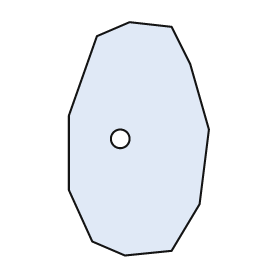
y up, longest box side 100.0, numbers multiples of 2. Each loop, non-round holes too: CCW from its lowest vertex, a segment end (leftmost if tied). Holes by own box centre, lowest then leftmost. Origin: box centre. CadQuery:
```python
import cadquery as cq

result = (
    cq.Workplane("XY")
    .moveTo(-6.0, -50.0)
    .lineTo(14.0, -48.0)
    .lineTo(26.0, -28.0)
    .lineTo(30.0, 4.0)
    .lineTo(22.0, 32.0)
    .lineTo(14.0, 48.0)
    .lineTo(-4.0, 50.0)
    .lineTo(-18.0, 44.0)
    .lineTo(-30.0, 10.0)
    .lineTo(-30.0, -22.0)
    .lineTo(-20.0, -44.0)
    .close()
    .moveTo(-8.0, 0.0)
    .circle(4.0)
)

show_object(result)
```